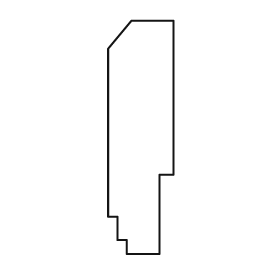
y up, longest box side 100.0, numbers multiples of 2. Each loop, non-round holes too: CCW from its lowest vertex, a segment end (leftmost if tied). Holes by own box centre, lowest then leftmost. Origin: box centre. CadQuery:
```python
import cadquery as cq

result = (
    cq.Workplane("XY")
    .moveTo(-6.0, -50.0)
    .lineTo(8.0, -50.0)
    .lineTo(8.0, -16.0)
    .lineTo(14.0, -16.0)
    .lineTo(14.0, 50.0)
    .lineTo(-4.0, 50.0)
    .lineTo(-14.0, 38.0)
    .lineTo(-14.0, -34.0)
    .lineTo(-10.0, -34.0)
    .lineTo(-10.0, -44.0)
    .lineTo(-6.0, -44.0)
    .close()
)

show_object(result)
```